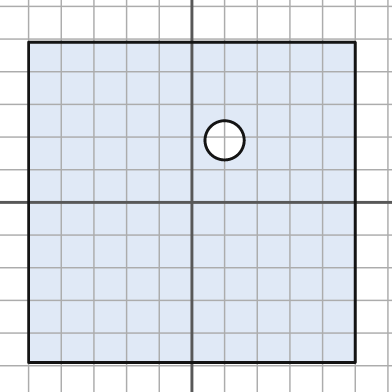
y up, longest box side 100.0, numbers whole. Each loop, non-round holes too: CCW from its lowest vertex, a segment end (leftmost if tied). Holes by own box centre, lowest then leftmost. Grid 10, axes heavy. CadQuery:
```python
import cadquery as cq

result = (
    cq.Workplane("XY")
    .moveTo(-50.0, -49.0)
    .lineTo(50.0, -49.0)
    .lineTo(50.0, 49.0)
    .lineTo(-50.0, 49.0)
    .close()
    .moveTo(10.0, 19.0)
    .circle(6.0)
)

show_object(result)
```